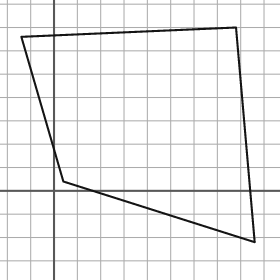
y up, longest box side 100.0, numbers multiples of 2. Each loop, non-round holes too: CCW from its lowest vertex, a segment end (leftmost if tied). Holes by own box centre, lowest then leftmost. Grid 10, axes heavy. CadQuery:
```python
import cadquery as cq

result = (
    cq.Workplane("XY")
    .moveTo(86.0, -22.0)
    .lineTo(78.0, 70.0)
    .lineTo(-14.0, 66.0)
    .lineTo(4.0, 4.0)
    .close()
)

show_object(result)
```